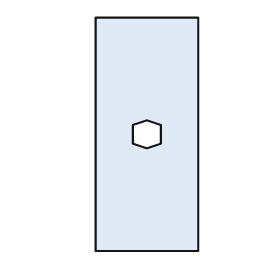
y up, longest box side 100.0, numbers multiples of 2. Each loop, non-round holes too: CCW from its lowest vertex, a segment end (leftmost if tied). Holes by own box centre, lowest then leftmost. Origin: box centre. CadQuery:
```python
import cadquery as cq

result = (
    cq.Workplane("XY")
    .moveTo(-22.0, -50.0)
    .lineTo(22.0, -50.0)
    .lineTo(22.0, 50.0)
    .lineTo(-22.0, 50.0)
    .close()
    .moveTo(0.0, -6.0)
    .lineTo(6.0, -4.0)
    .lineTo(6.0, 4.0)
    .lineTo(0.0, 6.0)
    .lineTo(-6.0, 4.0)
    .lineTo(-6.0, -4.0)
    .close()
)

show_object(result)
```